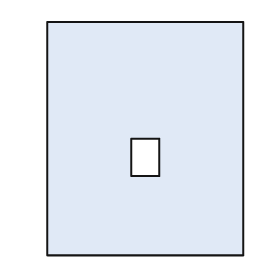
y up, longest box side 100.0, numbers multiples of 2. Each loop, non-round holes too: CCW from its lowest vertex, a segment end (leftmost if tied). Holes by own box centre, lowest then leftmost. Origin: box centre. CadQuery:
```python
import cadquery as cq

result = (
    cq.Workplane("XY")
    .moveTo(-42.0, -50.0)
    .lineTo(42.0, -50.0)
    .lineTo(42.0, 50.0)
    .lineTo(-42.0, 50.0)
    .close()
    .moveTo(-6.0, -16.0)
    .lineTo(6.0, -16.0)
    .lineTo(6.0, 0.0)
    .lineTo(-6.0, 0.0)
    .close()
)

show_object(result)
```